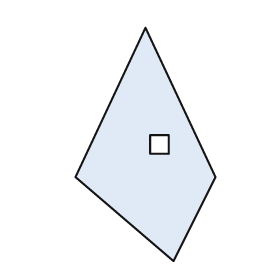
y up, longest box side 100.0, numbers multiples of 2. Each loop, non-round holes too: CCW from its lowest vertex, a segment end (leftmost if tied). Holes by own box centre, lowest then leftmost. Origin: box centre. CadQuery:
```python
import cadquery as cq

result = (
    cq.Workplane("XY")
    .moveTo(12.0, -50.0)
    .lineTo(30.0, -14.0)
    .lineTo(0.0, 50.0)
    .lineTo(-30.0, -14.0)
    .close()
    .moveTo(2.0, -4.0)
    .lineTo(10.0, -4.0)
    .lineTo(10.0, 4.0)
    .lineTo(2.0, 4.0)
    .close()
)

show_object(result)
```